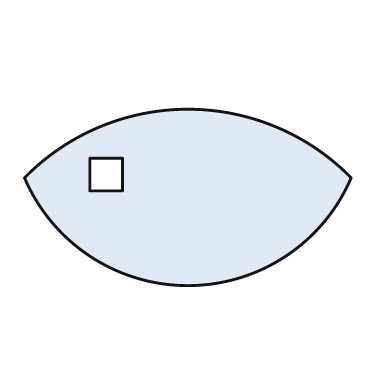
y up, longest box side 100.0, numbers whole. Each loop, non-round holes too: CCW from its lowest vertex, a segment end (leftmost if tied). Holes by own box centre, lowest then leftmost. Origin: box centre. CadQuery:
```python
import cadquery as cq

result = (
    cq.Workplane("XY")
    .moveTo(-50.0, 6.0)
    .threePointArc((0.0, -27.0), (50.0, 6.0))
    .threePointArc((0.0, 27.0), (-50.0, 6.0))
    .close()
    .moveTo(-30.0, 2.0)
    .lineTo(-20.0, 2.0)
    .lineTo(-20.0, 12.0)
    .lineTo(-30.0, 12.0)
    .close()
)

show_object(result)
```